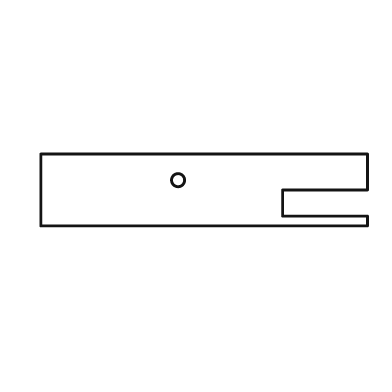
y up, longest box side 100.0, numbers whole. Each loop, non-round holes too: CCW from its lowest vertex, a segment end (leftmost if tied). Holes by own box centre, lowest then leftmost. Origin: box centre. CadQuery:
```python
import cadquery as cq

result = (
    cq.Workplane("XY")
    .moveTo(-50.0, -11.0)
    .lineTo(50.0, -11.0)
    .lineTo(50.0, -8.0)
    .lineTo(24.0, -8.0)
    .lineTo(24.0, 0.0)
    .lineTo(50.0, 0.0)
    .lineTo(50.0, 11.0)
    .lineTo(-50.0, 11.0)
    .close()
    .moveTo(-8.0, 3.0)
    .circle(2.0)
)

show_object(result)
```